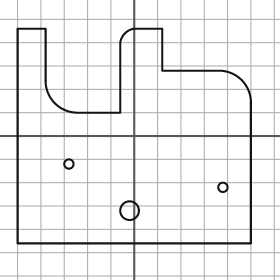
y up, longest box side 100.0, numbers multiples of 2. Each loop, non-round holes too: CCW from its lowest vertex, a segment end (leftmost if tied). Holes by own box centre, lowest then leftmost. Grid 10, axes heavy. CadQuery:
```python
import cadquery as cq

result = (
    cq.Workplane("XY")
    .moveTo(-50.0, -46.0)
    .lineTo(50.0, -46.0)
    .lineTo(50.0, 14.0)
    .threePointArc((46.0, 24.0), (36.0, 28.0))
    .lineTo(12.0, 28.0)
    .lineTo(12.0, 46.0)
    .lineTo(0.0, 46.0)
    .threePointArc((-4.0, 44.0), (-6.0, 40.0))
    .lineTo(-6.0, 10.0)
    .lineTo(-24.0, 10.0)
    .threePointArc((-34.0, 14.0), (-38.0, 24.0))
    .lineTo(-38.0, 46.0)
    .lineTo(-50.0, 46.0)
    .close()
    .moveTo(-2.0, -32.0)
    .circle(4.0)
    .moveTo(38.0, -22.0)
    .circle(2.0)
    .moveTo(-28.0, -12.0)
    .circle(2.0)
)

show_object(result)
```